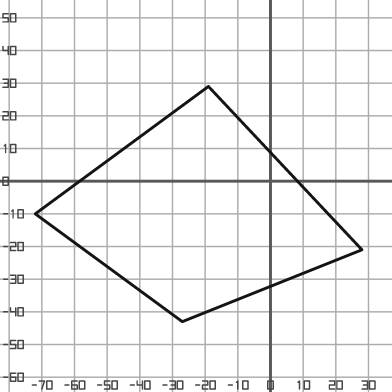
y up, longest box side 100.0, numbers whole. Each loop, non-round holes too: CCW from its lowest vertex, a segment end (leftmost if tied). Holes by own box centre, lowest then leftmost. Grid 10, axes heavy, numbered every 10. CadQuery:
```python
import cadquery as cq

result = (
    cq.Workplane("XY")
    .moveTo(-27.0, -43.0)
    .lineTo(28.0, -21.0)
    .lineTo(-19.0, 29.0)
    .lineTo(-72.0, -10.0)
    .close()
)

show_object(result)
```